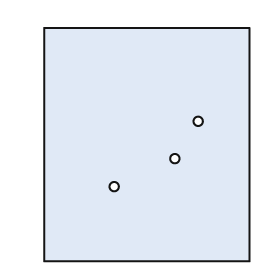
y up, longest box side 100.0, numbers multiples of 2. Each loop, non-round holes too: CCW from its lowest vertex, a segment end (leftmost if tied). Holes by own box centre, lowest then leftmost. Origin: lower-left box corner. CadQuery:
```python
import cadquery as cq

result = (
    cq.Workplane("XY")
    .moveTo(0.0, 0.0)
    .lineTo(88.0, 0.0)
    .lineTo(88.0, 100.0)
    .lineTo(0.0, 100.0)
    .close()
    .moveTo(30.0, 32.0)
    .circle(2.0)
    .moveTo(56.0, 44.0)
    .circle(2.0)
    .moveTo(66.0, 60.0)
    .circle(2.0)
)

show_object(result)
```